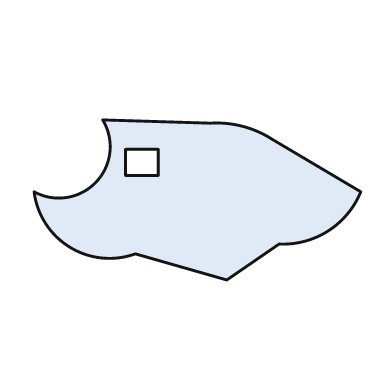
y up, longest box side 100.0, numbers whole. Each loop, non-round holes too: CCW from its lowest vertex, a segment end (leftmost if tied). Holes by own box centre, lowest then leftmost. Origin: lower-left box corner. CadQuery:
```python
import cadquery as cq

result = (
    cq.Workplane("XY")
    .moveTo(59.0, 0.0)
    .lineTo(75.0, 11.0)
    .threePointArc((90.0, 15.0), (100.0, 27.0))
    .lineTo(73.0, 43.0)
    .threePointArc((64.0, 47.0), (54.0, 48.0))
    .lineTo(21.0, 49.0)
    .threePointArc((19.0, 30.0), (0.0, 27.0))
    .threePointArc((11.0, 10.0), (31.0, 8.0))
    .close()
    .moveTo(28.0, 32.0)
    .lineTo(38.0, 32.0)
    .lineTo(38.0, 40.0)
    .lineTo(28.0, 40.0)
    .close()
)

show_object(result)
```